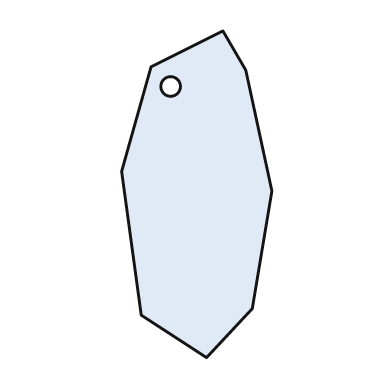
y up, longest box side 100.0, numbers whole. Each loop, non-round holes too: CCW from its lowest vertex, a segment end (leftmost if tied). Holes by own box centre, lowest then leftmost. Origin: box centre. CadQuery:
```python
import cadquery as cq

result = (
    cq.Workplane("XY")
    .moveTo(3.0, -50.0)
    .lineTo(17.0, -35.0)
    .lineTo(23.0, 1.0)
    .lineTo(15.0, 38.0)
    .lineTo(8.0, 50.0)
    .lineTo(-14.0, 39.0)
    .lineTo(-23.0, 7.0)
    .lineTo(-17.0, -37.0)
    .close()
    .moveTo(-8.0, 33.0)
    .circle(3.0)
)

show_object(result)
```